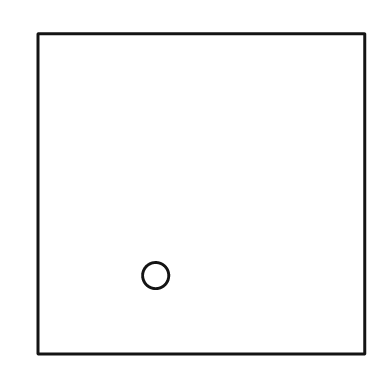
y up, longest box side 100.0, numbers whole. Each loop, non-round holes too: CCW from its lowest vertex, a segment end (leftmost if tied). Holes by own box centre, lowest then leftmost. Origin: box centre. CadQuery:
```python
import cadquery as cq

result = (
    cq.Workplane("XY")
    .moveTo(-50.0, -49.0)
    .lineTo(50.0, -49.0)
    .lineTo(50.0, 49.0)
    .lineTo(-50.0, 49.0)
    .close()
    .moveTo(-14.0, -25.0)
    .circle(4.0)
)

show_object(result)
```